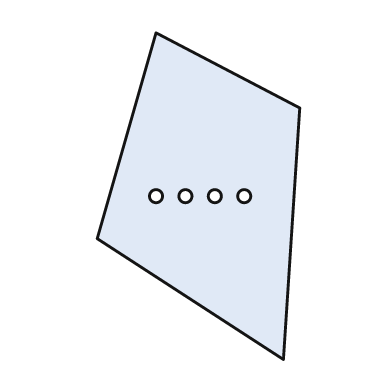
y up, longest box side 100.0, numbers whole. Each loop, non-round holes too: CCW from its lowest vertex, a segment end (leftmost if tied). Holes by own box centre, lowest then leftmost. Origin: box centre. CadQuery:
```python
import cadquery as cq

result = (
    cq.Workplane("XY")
    .moveTo(26.0, -50.0)
    .lineTo(31.0, 27.0)
    .lineTo(-13.0, 50.0)
    .lineTo(-31.0, -13.0)
    .close()
    .moveTo(-13.0, 0.0)
    .circle(2.0)
    .moveTo(-4.0, 0.0)
    .circle(2.0)
    .moveTo(5.0, 0.0)
    .circle(2.0)
    .moveTo(14.0, 0.0)
    .circle(2.0)
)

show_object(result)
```